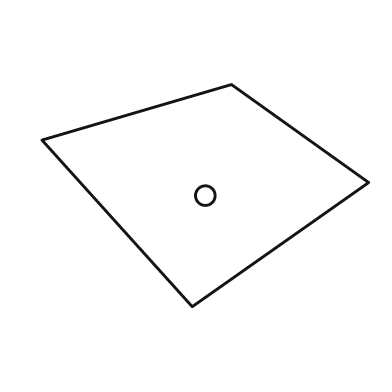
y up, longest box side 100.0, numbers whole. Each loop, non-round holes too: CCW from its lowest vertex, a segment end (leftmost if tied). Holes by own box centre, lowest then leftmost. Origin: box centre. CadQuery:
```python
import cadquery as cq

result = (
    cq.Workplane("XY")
    .moveTo(-4.0, -34.0)
    .lineTo(50.0, 4.0)
    .lineTo(8.0, 34.0)
    .lineTo(-50.0, 17.0)
    .close()
    .moveTo(0.0, 0.0)
    .circle(3.0)
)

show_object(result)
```